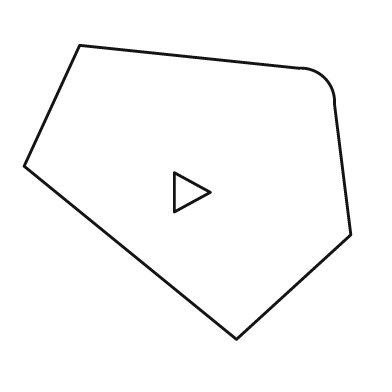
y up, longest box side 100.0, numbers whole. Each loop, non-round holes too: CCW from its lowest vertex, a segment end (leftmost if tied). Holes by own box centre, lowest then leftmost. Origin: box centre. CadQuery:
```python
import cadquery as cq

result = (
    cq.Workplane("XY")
    .moveTo(15.0, -45.0)
    .lineTo(50.0, -13.0)
    .lineTo(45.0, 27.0)
    .threePointArc((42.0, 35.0), (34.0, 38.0))
    .lineTo(-33.0, 45.0)
    .lineTo(-50.0, 8.0)
    .close()
    .moveTo(-4.0, -6.0)
    .lineTo(7.0, 0.0)
    .lineTo(-4.0, 6.0)
    .close()
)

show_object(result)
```